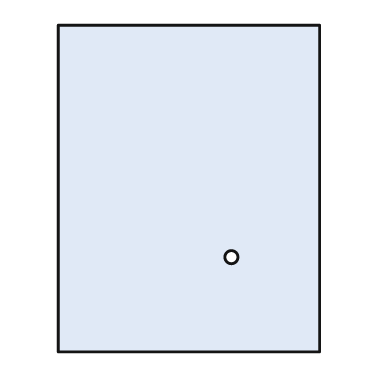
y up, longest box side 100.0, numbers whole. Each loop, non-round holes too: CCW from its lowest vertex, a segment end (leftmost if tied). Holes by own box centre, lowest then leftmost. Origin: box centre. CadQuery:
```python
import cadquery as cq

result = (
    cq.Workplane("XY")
    .moveTo(-40.0, -50.0)
    .lineTo(40.0, -50.0)
    .lineTo(40.0, 50.0)
    .lineTo(-40.0, 50.0)
    .close()
    .moveTo(13.0, -21.0)
    .circle(2.0)
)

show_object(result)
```